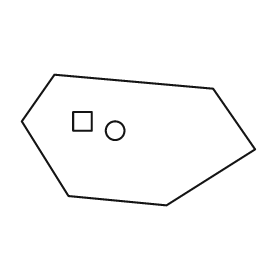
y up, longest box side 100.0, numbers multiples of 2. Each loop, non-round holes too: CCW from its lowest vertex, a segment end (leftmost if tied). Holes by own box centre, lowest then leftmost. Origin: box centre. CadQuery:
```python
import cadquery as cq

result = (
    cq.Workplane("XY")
    .moveTo(12.0, -28.0)
    .lineTo(50.0, -4.0)
    .lineTo(32.0, 22.0)
    .lineTo(-36.0, 28.0)
    .lineTo(-50.0, 8.0)
    .lineTo(-30.0, -24.0)
    .close()
    .moveTo(-10.0, 4.0)
    .circle(4.0)
    .moveTo(-28.0, 4.0)
    .lineTo(-20.0, 4.0)
    .lineTo(-20.0, 12.0)
    .lineTo(-28.0, 12.0)
    .close()
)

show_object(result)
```